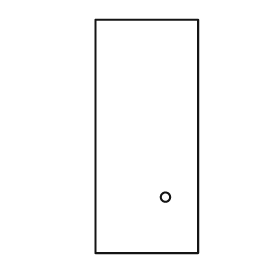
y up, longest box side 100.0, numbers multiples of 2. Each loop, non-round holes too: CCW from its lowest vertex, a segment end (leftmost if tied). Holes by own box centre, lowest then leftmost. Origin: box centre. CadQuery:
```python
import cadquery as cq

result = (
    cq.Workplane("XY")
    .moveTo(-22.0, -50.0)
    .lineTo(22.0, -50.0)
    .lineTo(22.0, 50.0)
    .lineTo(-22.0, 50.0)
    .close()
    .moveTo(8.0, -26.0)
    .circle(2.0)
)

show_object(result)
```